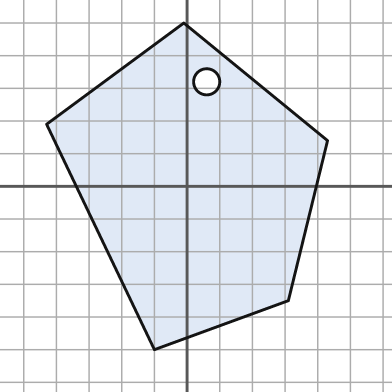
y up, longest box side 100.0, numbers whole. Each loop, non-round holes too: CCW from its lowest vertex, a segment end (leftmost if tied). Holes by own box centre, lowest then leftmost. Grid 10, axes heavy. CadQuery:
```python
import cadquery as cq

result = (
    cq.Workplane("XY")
    .moveTo(-10.0, -50.0)
    .lineTo(31.0, -35.0)
    .lineTo(43.0, 14.0)
    .lineTo(-1.0, 50.0)
    .lineTo(-43.0, 19.0)
    .close()
    .moveTo(6.0, 32.0)
    .circle(4.0)
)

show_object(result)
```